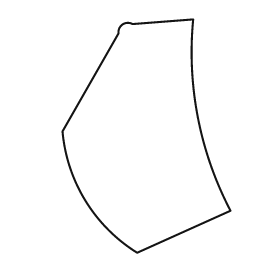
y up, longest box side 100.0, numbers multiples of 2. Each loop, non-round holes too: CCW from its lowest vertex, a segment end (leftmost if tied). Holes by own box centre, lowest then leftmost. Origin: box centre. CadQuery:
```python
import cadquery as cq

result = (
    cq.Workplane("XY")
    .moveTo(-4.0, -50.0)
    .lineTo(36.0, -32.0)
    .threePointArc((22.0, 8.0), (20.0, 50.0))
    .lineTo(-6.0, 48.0)
    .threePointArc((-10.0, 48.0), (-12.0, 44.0))
    .lineTo(-36.0, 2.0)
    .threePointArc((-26.0, -28.0), (-4.0, -50.0))
    .close()
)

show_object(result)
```